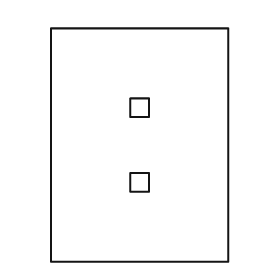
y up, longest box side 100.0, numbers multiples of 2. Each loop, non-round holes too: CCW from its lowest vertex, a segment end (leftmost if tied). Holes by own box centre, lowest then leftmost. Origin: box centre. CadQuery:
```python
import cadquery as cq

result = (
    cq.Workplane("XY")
    .moveTo(-38.0, -50.0)
    .lineTo(38.0, -50.0)
    .lineTo(38.0, 50.0)
    .lineTo(-38.0, 50.0)
    .close()
    .moveTo(-4.0, -20.0)
    .lineTo(4.0, -20.0)
    .lineTo(4.0, -12.0)
    .lineTo(-4.0, -12.0)
    .close()
    .moveTo(-4.0, 12.0)
    .lineTo(4.0, 12.0)
    .lineTo(4.0, 20.0)
    .lineTo(-4.0, 20.0)
    .close()
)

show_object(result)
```